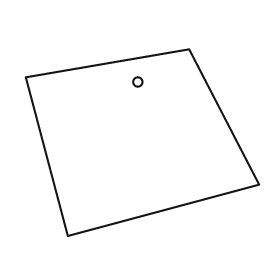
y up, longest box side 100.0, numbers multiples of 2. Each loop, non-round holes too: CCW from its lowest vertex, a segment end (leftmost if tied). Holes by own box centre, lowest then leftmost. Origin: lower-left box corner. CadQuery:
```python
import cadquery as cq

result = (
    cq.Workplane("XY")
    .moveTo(18.0, 0.0)
    .lineTo(100.0, 22.0)
    .lineTo(70.0, 80.0)
    .lineTo(0.0, 68.0)
    .close()
    .moveTo(48.0, 66.0)
    .circle(2.0)
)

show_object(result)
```